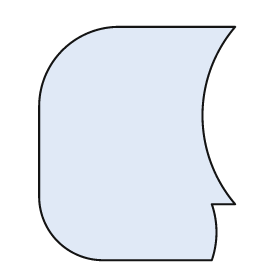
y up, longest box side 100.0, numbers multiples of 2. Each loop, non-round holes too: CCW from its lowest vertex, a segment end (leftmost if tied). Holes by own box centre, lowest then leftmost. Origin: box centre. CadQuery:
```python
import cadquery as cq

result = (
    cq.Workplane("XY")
    .moveTo(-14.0, -50.0)
    .lineTo(32.0, -50.0)
    .threePointArc((34.0, -38.0), (32.0, -26.0))
    .lineTo(42.0, -26.0)
    .threePointArc((28.0, 12.0), (42.0, 50.0))
    .lineTo(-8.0, 50.0)
    .threePointArc((-32.0, 40.0), (-42.0, 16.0))
    .lineTo(-42.0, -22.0)
    .threePointArc((-34.0, -42.0), (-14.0, -50.0))
    .close()
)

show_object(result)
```